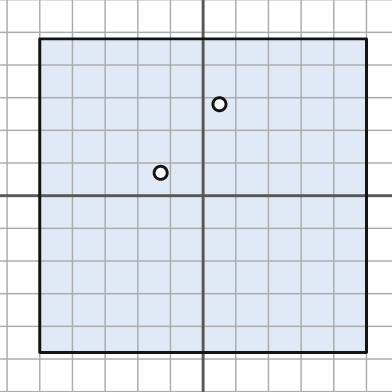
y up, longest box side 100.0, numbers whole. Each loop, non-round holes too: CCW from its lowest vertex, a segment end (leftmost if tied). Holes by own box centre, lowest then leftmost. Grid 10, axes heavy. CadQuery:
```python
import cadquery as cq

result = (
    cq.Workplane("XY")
    .moveTo(-50.0, -48.0)
    .lineTo(50.0, -48.0)
    .lineTo(50.0, 48.0)
    .lineTo(-50.0, 48.0)
    .close()
    .moveTo(-13.0, 7.0)
    .circle(2.0)
    .moveTo(5.0, 28.0)
    .circle(2.0)
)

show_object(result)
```